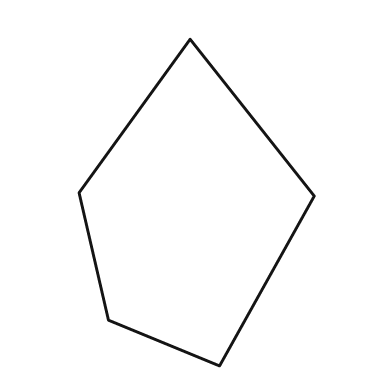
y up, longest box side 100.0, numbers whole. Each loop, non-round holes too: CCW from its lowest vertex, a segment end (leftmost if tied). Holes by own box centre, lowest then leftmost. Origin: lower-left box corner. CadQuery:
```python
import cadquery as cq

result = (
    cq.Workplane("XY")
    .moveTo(43.0, 0.0)
    .lineTo(72.0, 52.0)
    .lineTo(34.0, 100.0)
    .lineTo(0.0, 53.0)
    .lineTo(9.0, 14.0)
    .close()
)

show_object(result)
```